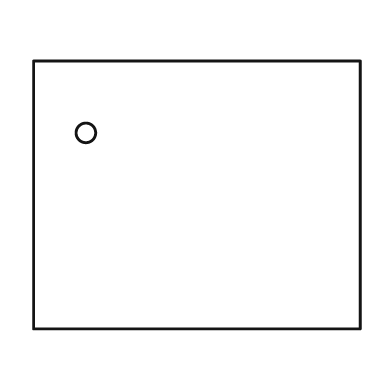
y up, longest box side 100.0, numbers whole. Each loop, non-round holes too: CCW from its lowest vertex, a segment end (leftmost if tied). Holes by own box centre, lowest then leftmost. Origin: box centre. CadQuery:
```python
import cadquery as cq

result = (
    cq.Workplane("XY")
    .moveTo(-50.0, -41.0)
    .lineTo(50.0, -41.0)
    .lineTo(50.0, 41.0)
    .lineTo(-50.0, 41.0)
    .close()
    .moveTo(-34.0, 19.0)
    .circle(3.0)
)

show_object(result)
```